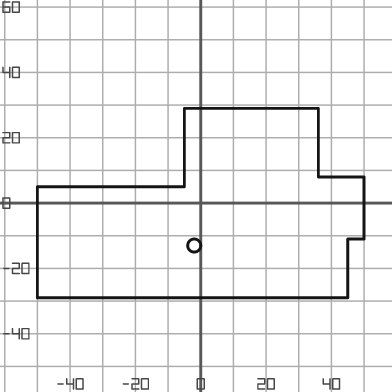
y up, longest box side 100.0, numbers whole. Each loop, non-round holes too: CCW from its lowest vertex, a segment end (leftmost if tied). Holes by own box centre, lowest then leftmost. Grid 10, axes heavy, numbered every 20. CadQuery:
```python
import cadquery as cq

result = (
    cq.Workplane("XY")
    .moveTo(-50.0, -29.0)
    .lineTo(45.0, -29.0)
    .lineTo(45.0, -11.0)
    .lineTo(50.0, -11.0)
    .lineTo(50.0, 8.0)
    .lineTo(36.0, 8.0)
    .lineTo(36.0, 29.0)
    .lineTo(-5.0, 29.0)
    .lineTo(-5.0, 5.0)
    .lineTo(-50.0, 5.0)
    .close()
    .moveTo(-2.0, -13.0)
    .circle(2.0)
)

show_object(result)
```